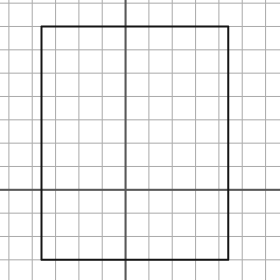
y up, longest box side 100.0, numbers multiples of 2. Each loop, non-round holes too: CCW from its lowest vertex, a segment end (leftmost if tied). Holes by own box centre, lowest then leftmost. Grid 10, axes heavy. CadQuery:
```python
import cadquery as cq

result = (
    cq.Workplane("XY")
    .moveTo(-36.0, -30.0)
    .lineTo(44.0, -30.0)
    .lineTo(44.0, 70.0)
    .lineTo(-36.0, 70.0)
    .close()
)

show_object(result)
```